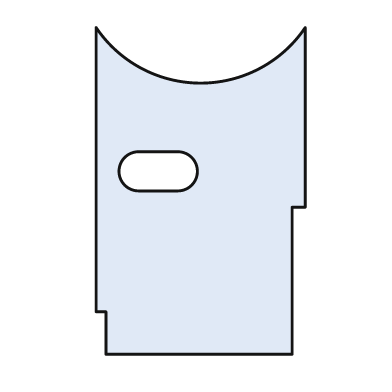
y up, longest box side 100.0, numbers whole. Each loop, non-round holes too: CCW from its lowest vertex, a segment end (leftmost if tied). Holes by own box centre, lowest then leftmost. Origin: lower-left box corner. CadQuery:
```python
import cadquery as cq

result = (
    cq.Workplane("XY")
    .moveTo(3.0, 0.0)
    .lineTo(60.0, 0.0)
    .lineTo(60.0, 45.0)
    .lineTo(64.0, 45.0)
    .lineTo(64.0, 100.0)
    .threePointArc((32.0, 83.0), (0.0, 100.0))
    .lineTo(0.0, 13.0)
    .lineTo(3.0, 13.0)
    .close()
    .moveTo(13.0, 50.0)
    .lineTo(25.0, 50.0)
    .threePointArc((31.0, 56.0), (25.0, 62.0))
    .lineTo(13.0, 62.0)
    .threePointArc((7.0, 56.0), (13.0, 50.0))
    .close()
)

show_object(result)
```